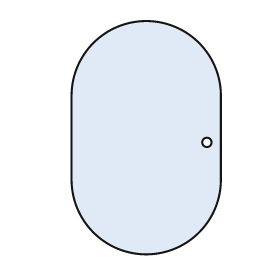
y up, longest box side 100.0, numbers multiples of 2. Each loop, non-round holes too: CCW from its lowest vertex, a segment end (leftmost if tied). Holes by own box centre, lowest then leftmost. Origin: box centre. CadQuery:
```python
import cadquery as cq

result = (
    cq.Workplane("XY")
    .moveTo(-32.0, -18.0)
    .threePointArc((0.0, -50.0), (32.0, -18.0))
    .lineTo(32.0, 18.0)
    .threePointArc((0.0, 50.0), (-32.0, 18.0))
    .close()
    .moveTo(26.0, -2.0)
    .circle(2.0)
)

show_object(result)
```